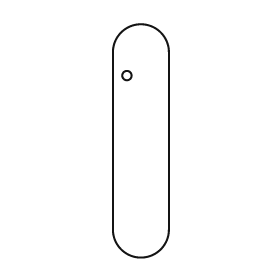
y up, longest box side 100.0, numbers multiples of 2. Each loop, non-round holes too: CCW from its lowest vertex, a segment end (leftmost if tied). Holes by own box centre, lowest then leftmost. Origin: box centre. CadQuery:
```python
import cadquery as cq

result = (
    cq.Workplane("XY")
    .moveTo(-12.0, -38.0)
    .threePointArc((0.0, -50.0), (12.0, -38.0))
    .lineTo(12.0, 38.0)
    .threePointArc((0.0, 50.0), (-12.0, 38.0))
    .close()
    .moveTo(-6.0, 28.0)
    .circle(2.0)
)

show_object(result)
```